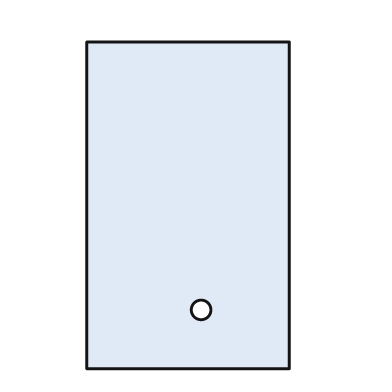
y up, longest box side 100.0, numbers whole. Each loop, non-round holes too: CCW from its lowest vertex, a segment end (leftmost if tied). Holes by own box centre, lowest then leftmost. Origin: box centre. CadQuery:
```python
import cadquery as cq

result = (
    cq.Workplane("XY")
    .moveTo(-31.0, -50.0)
    .lineTo(31.0, -50.0)
    .lineTo(31.0, 50.0)
    .lineTo(-31.0, 50.0)
    .close()
    .moveTo(4.0, -32.0)
    .circle(3.0)
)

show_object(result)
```